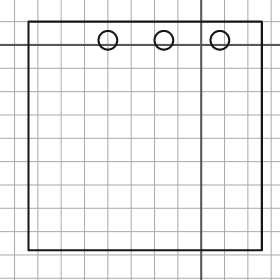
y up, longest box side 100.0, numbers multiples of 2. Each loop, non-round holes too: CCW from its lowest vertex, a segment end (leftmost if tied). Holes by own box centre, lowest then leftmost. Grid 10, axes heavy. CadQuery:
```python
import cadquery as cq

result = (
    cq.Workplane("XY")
    .moveTo(-74.0, -88.0)
    .lineTo(26.0, -88.0)
    .lineTo(26.0, 10.0)
    .lineTo(-74.0, 10.0)
    .close()
    .moveTo(-40.0, 2.0)
    .circle(4.0)
    .moveTo(-16.0, 2.0)
    .circle(4.0)
    .moveTo(8.0, 2.0)
    .circle(4.0)
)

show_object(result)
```